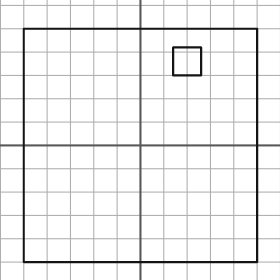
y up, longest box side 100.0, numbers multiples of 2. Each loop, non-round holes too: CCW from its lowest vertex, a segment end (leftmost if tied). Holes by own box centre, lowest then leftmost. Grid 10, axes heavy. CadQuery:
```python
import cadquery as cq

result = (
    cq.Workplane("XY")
    .moveTo(-50.0, -50.0)
    .lineTo(50.0, -50.0)
    .lineTo(50.0, 50.0)
    .lineTo(-50.0, 50.0)
    .close()
    .moveTo(14.0, 30.0)
    .lineTo(26.0, 30.0)
    .lineTo(26.0, 42.0)
    .lineTo(14.0, 42.0)
    .close()
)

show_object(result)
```